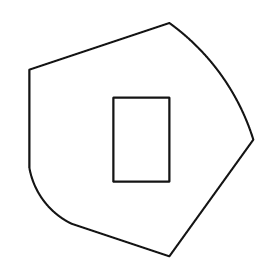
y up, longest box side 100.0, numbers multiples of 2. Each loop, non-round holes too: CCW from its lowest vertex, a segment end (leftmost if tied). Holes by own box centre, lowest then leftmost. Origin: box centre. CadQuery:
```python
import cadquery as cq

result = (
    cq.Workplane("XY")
    .moveTo(12.0, -50.0)
    .lineTo(48.0, 0.0)
    .threePointArc((34.0, 28.0), (12.0, 50.0))
    .lineTo(-48.0, 30.0)
    .lineTo(-48.0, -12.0)
    .threePointArc((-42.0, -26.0), (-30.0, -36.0))
    .close()
    .moveTo(-12.0, -18.0)
    .lineTo(12.0, -18.0)
    .lineTo(12.0, 18.0)
    .lineTo(-12.0, 18.0)
    .close()
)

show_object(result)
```